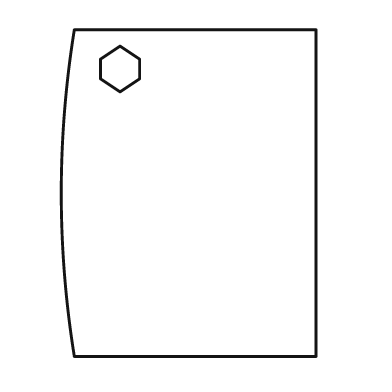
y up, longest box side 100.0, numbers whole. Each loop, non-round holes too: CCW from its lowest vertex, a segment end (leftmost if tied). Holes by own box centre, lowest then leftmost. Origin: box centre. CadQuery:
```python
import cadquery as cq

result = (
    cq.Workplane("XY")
    .moveTo(-35.0, -50.0)
    .lineTo(39.0, -50.0)
    .lineTo(39.0, 50.0)
    .lineTo(-35.0, 50.0)
    .threePointArc((-39.0, 0.0), (-35.0, -50.0))
    .close()
    .moveTo(-21.0, 31.0)
    .lineTo(-15.0, 35.0)
    .lineTo(-15.0, 41.0)
    .lineTo(-21.0, 45.0)
    .lineTo(-27.0, 41.0)
    .lineTo(-27.0, 35.0)
    .close()
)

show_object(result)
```